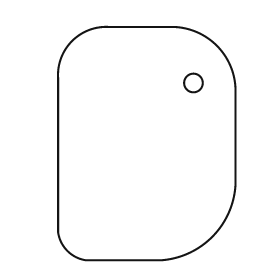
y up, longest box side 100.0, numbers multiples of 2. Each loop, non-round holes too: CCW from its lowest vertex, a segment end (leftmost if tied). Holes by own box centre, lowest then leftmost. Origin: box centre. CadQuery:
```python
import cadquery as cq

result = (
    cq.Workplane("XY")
    .moveTo(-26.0, -50.0)
    .lineTo(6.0, -50.0)
    .threePointArc((28.0, -40.0), (38.0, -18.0))
    .lineTo(38.0, 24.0)
    .threePointArc((30.0, 42.0), (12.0, 50.0))
    .lineTo(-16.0, 50.0)
    .threePointArc((-32.0, 44.0), (-38.0, 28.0))
    .lineTo(-38.0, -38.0)
    .threePointArc((-34.0, -46.0), (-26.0, -50.0))
    .close()
    .moveTo(20.0, 26.0)
    .circle(4.0)
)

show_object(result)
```